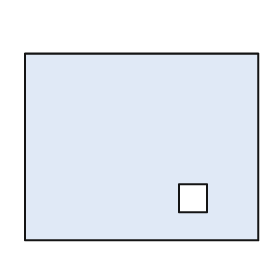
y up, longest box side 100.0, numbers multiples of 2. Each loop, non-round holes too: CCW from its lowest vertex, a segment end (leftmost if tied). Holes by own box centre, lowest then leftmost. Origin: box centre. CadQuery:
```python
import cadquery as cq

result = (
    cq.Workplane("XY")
    .moveTo(-50.0, -40.0)
    .lineTo(50.0, -40.0)
    .lineTo(50.0, 40.0)
    .lineTo(-50.0, 40.0)
    .close()
    .moveTo(16.0, -28.0)
    .lineTo(28.0, -28.0)
    .lineTo(28.0, -16.0)
    .lineTo(16.0, -16.0)
    .close()
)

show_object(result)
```